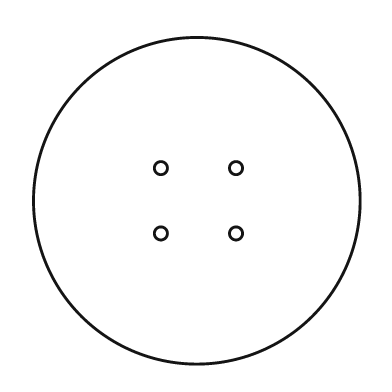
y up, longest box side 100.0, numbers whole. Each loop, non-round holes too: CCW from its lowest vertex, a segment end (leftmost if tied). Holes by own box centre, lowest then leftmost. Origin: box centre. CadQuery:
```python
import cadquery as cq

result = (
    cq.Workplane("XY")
    .moveTo(0.0, 0.0)
    .circle(50.0)
    .moveTo(-11.0, -10.0)
    .circle(2.0)
    .moveTo(12.0, -10.0)
    .circle(2.0)
    .moveTo(-11.0, 10.0)
    .circle(2.0)
    .moveTo(12.0, 10.0)
    .circle(2.0)
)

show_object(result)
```